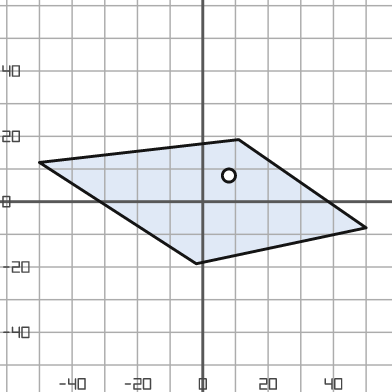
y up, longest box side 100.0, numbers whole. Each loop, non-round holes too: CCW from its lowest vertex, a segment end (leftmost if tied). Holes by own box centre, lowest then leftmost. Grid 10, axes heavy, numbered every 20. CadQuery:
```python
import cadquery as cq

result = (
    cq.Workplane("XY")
    .moveTo(-2.0, -19.0)
    .lineTo(50.0, -8.0)
    .lineTo(11.0, 19.0)
    .lineTo(-50.0, 12.0)
    .close()
    .moveTo(8.0, 8.0)
    .circle(2.0)
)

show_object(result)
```